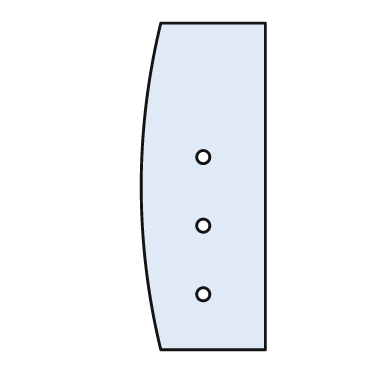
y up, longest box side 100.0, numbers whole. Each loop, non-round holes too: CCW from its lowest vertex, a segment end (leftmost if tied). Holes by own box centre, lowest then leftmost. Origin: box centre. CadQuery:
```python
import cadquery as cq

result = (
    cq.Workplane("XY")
    .moveTo(-13.0, -50.0)
    .lineTo(19.0, -50.0)
    .lineTo(19.0, 50.0)
    .lineTo(-13.0, 50.0)
    .threePointArc((-19.0, 0.0), (-13.0, -50.0))
    .close()
    .moveTo(0.0, -33.0)
    .circle(2.0)
    .moveTo(0.0, -12.0)
    .circle(2.0)
    .moveTo(0.0, 9.0)
    .circle(2.0)
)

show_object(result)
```